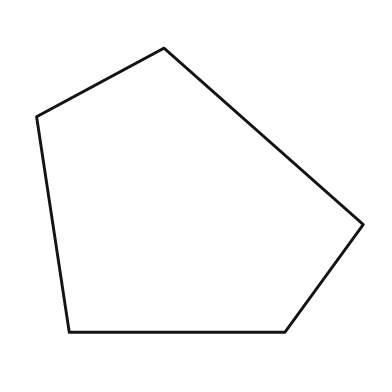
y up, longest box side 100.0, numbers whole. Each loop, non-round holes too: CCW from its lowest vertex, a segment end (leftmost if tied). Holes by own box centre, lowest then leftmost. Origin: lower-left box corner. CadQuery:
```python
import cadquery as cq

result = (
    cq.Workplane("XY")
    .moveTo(10.0, 0.0)
    .lineTo(76.0, 0.0)
    .lineTo(100.0, 33.0)
    .lineTo(39.0, 87.0)
    .lineTo(0.0, 66.0)
    .close()
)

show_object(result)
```